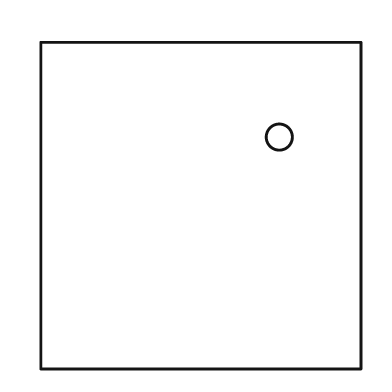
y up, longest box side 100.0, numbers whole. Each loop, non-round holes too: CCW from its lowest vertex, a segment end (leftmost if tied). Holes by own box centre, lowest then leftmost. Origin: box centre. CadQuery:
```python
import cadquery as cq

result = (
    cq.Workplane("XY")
    .moveTo(-49.0, -50.0)
    .lineTo(49.0, -50.0)
    .lineTo(49.0, 50.0)
    .lineTo(-49.0, 50.0)
    .close()
    .moveTo(24.0, 21.0)
    .circle(4.0)
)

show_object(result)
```